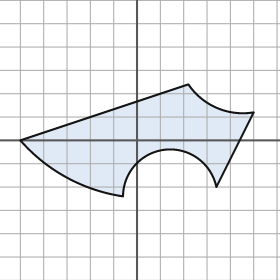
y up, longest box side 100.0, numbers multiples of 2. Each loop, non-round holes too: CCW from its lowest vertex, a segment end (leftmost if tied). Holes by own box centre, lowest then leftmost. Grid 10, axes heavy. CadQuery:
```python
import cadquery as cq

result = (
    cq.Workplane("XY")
    .moveTo(-6.0, -24.0)
    .threePointArc((12.0, -4.0), (34.0, -20.0))
    .lineTo(50.0, 12.0)
    .threePointArc((34.0, 14.0), (22.0, 24.0))
    .lineTo(-50.0, 0.0)
    .threePointArc((-30.0, -16.0), (-6.0, -24.0))
    .close()
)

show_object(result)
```